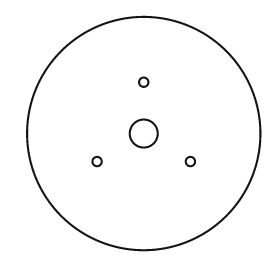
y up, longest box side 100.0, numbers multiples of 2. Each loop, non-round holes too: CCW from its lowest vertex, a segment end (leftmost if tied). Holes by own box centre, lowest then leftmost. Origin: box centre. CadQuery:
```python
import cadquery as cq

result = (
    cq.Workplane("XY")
    .moveTo(0.0, 0.0)
    .circle(50.0)
    .moveTo(-20.0, -12.0)
    .circle(2.0)
    .moveTo(20.0, -12.0)
    .circle(2.0)
    .moveTo(0.0, 0.0)
    .circle(6.0)
    .moveTo(0.0, 22.0)
    .circle(2.0)
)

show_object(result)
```